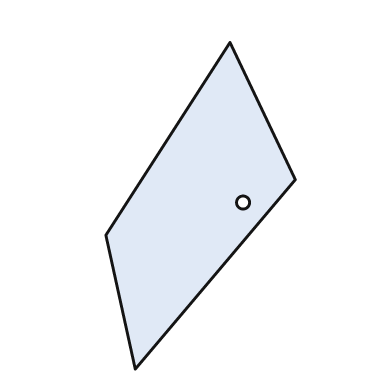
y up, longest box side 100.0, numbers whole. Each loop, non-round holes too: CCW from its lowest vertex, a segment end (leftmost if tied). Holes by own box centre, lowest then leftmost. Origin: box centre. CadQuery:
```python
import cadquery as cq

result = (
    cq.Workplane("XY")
    .moveTo(-20.0, -50.0)
    .lineTo(29.0, 8.0)
    .lineTo(9.0, 50.0)
    .lineTo(-29.0, -9.0)
    .close()
    .moveTo(13.0, 1.0)
    .circle(2.0)
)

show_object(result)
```